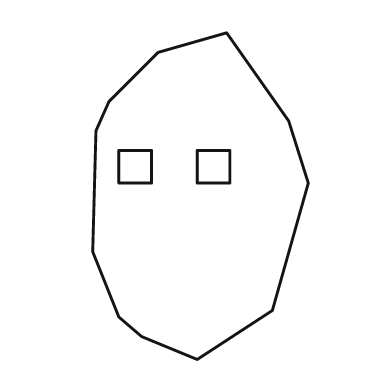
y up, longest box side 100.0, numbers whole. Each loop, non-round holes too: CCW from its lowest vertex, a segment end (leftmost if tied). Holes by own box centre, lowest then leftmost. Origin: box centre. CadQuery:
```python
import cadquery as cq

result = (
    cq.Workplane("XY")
    .moveTo(-1.0, -50.0)
    .lineTo(22.0, -35.0)
    .lineTo(33.0, 4.0)
    .lineTo(27.0, 23.0)
    .lineTo(8.0, 50.0)
    .lineTo(-13.0, 44.0)
    .lineTo(-28.0, 29.0)
    .lineTo(-32.0, 20.0)
    .lineTo(-33.0, -17.0)
    .lineTo(-25.0, -37.0)
    .lineTo(-18.0, -43.0)
    .close()
    .moveTo(-25.0, 4.0)
    .lineTo(-15.0, 4.0)
    .lineTo(-15.0, 14.0)
    .lineTo(-25.0, 14.0)
    .close()
    .moveTo(-1.0, 4.0)
    .lineTo(9.0, 4.0)
    .lineTo(9.0, 14.0)
    .lineTo(-1.0, 14.0)
    .close()
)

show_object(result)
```